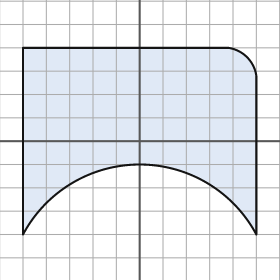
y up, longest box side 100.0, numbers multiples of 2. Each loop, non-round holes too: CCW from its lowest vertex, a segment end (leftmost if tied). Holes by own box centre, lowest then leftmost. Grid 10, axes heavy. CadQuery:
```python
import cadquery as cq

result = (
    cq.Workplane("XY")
    .moveTo(-50.0, -40.0)
    .threePointArc((0.0, -10.0), (50.0, -40.0))
    .lineTo(50.0, 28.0)
    .threePointArc((46.0, 36.0), (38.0, 40.0))
    .lineTo(-50.0, 40.0)
    .close()
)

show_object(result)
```